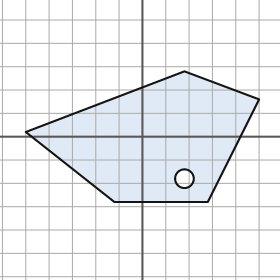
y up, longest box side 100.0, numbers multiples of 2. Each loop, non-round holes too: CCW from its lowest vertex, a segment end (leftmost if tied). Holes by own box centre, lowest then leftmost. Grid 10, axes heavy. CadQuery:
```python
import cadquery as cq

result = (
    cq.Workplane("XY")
    .moveTo(-12.0, -28.0)
    .lineTo(28.0, -28.0)
    .lineTo(50.0, 16.0)
    .lineTo(18.0, 28.0)
    .lineTo(-50.0, 2.0)
    .close()
    .moveTo(18.0, -18.0)
    .circle(4.0)
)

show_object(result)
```